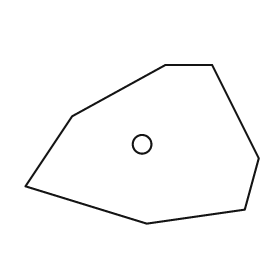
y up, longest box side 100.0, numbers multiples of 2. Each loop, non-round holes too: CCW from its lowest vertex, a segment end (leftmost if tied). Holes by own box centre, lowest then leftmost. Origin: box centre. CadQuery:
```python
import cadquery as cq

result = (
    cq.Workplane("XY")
    .moveTo(2.0, -34.0)
    .lineTo(44.0, -28.0)
    .lineTo(50.0, -6.0)
    .lineTo(30.0, 34.0)
    .lineTo(10.0, 34.0)
    .lineTo(-30.0, 12.0)
    .lineTo(-50.0, -18.0)
    .close()
    .moveTo(0.0, 0.0)
    .circle(4.0)
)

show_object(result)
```